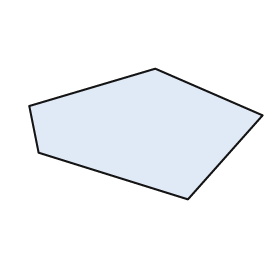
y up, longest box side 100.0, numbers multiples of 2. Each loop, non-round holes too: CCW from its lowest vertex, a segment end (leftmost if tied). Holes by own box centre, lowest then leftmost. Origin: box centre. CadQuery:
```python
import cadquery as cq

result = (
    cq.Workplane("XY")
    .moveTo(18.0, -28.0)
    .lineTo(50.0, 8.0)
    .lineTo(4.0, 28.0)
    .lineTo(-50.0, 12.0)
    .lineTo(-46.0, -8.0)
    .close()
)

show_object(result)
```